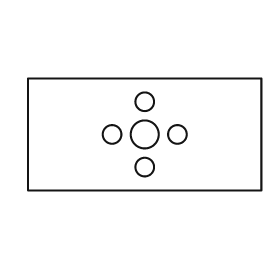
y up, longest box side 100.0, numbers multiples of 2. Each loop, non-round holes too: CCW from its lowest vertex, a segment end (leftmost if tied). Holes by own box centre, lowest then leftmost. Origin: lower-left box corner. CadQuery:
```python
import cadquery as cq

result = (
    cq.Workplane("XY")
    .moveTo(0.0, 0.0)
    .lineTo(100.0, 0.0)
    .lineTo(100.0, 48.0)
    .lineTo(0.0, 48.0)
    .close()
    .moveTo(50.0, 10.0)
    .circle(4.0)
    .moveTo(36.0, 24.0)
    .circle(4.0)
    .moveTo(50.0, 24.0)
    .circle(6.0)
    .moveTo(64.0, 24.0)
    .circle(4.0)
    .moveTo(50.0, 38.0)
    .circle(4.0)
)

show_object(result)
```